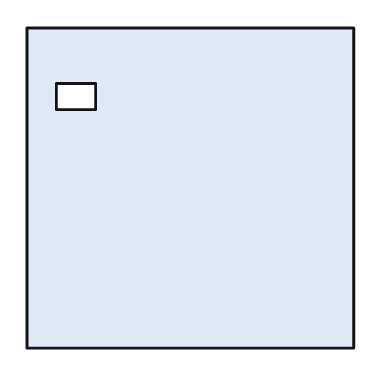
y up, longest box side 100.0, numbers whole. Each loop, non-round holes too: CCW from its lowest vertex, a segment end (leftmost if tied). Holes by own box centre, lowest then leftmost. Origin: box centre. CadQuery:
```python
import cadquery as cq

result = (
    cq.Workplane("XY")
    .moveTo(-50.0, -49.0)
    .lineTo(50.0, -49.0)
    .lineTo(50.0, 49.0)
    .lineTo(-50.0, 49.0)
    .close()
    .moveTo(-41.0, 24.0)
    .lineTo(-29.0, 24.0)
    .lineTo(-29.0, 32.0)
    .lineTo(-41.0, 32.0)
    .close()
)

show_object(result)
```